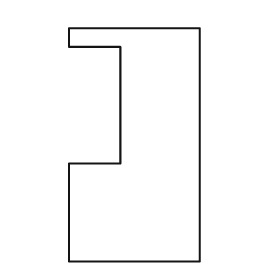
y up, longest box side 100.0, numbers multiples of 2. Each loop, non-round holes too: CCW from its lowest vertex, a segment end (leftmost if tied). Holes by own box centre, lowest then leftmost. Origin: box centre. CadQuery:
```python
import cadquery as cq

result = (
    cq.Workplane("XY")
    .moveTo(-28.0, -50.0)
    .lineTo(28.0, -50.0)
    .lineTo(28.0, 50.0)
    .lineTo(-28.0, 50.0)
    .lineTo(-28.0, 42.0)
    .lineTo(-6.0, 42.0)
    .lineTo(-6.0, -8.0)
    .lineTo(-28.0, -8.0)
    .close()
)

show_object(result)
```